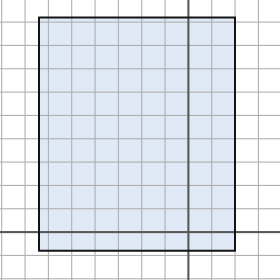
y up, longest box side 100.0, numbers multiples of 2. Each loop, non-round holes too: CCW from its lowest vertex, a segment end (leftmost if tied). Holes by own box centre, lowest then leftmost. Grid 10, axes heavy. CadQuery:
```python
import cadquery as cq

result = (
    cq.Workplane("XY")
    .moveTo(-64.0, -8.0)
    .lineTo(20.0, -8.0)
    .lineTo(20.0, 92.0)
    .lineTo(-64.0, 92.0)
    .close()
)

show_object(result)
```